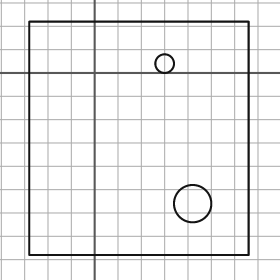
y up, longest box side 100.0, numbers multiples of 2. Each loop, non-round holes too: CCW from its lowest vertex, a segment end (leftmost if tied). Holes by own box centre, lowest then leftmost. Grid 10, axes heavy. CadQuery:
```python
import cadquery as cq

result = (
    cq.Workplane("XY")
    .moveTo(-28.0, -78.0)
    .lineTo(66.0, -78.0)
    .lineTo(66.0, 22.0)
    .lineTo(-28.0, 22.0)
    .close()
    .moveTo(42.0, -56.0)
    .circle(8.0)
    .moveTo(30.0, 4.0)
    .circle(4.0)
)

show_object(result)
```